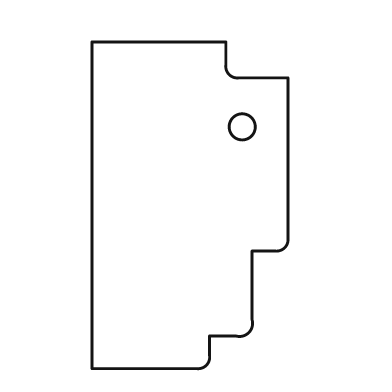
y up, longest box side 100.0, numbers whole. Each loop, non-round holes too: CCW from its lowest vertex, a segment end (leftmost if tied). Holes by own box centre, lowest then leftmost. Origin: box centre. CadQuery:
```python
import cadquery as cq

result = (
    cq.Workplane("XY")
    .moveTo(-30.0, -50.0)
    .lineTo(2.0, -50.0)
    .threePointArc((5.0, -49.0), (6.0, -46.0))
    .lineTo(6.0, -40.0)
    .lineTo(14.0, -40.0)
    .threePointArc((18.0, -39.0), (19.0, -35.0))
    .lineTo(19.0, -14.0)
    .lineTo(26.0, -14.0)
    .threePointArc((29.0, -13.0), (30.0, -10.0))
    .lineTo(30.0, 39.0)
    .lineTo(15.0, 39.0)
    .threePointArc((12.0, 40.0), (11.0, 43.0))
    .lineTo(11.0, 50.0)
    .lineTo(-30.0, 50.0)
    .close()
    .moveTo(16.0, 24.0)
    .circle(4.0)
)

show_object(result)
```